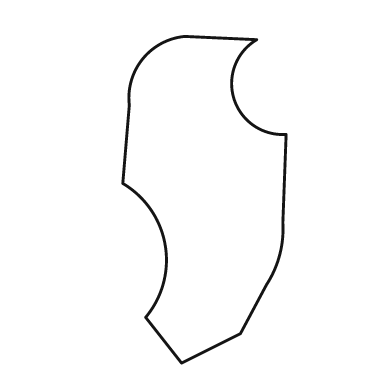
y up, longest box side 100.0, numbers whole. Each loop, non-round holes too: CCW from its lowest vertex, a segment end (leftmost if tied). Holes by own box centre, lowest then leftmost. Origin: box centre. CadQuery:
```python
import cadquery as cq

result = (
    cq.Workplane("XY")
    .moveTo(-7.0, -50.0)
    .lineTo(11.0, -41.0)
    .lineTo(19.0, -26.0)
    .threePointArc((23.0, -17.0), (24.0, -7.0))
    .lineTo(25.0, 20.0)
    .threePointArc((9.0, 31.0), (16.0, 49.0))
    .lineTo(-6.0, 50.0)
    .threePointArc((-19.0, 43.0), (-23.0, 29.0))
    .lineTo(-25.0, 5.0)
    .threePointArc((-12.0, -14.0), (-18.0, -36.0))
    .close()
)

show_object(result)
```